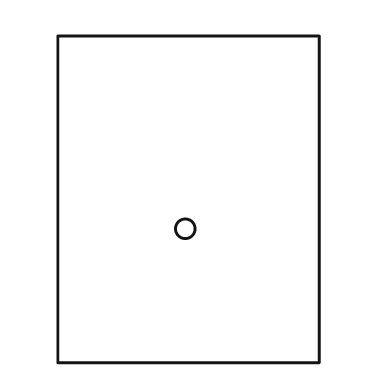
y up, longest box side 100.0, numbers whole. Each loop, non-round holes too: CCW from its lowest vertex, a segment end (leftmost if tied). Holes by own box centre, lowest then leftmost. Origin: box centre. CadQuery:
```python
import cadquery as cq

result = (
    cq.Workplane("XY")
    .moveTo(-40.0, -50.0)
    .lineTo(40.0, -50.0)
    .lineTo(40.0, 50.0)
    .lineTo(-40.0, 50.0)
    .close()
    .moveTo(-1.0, -9.0)
    .circle(3.0)
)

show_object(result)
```